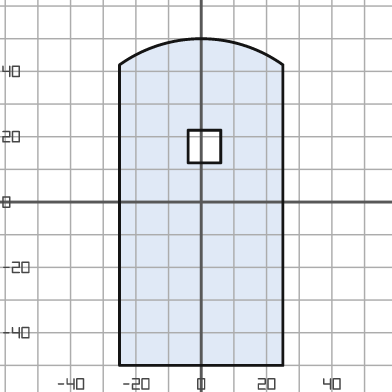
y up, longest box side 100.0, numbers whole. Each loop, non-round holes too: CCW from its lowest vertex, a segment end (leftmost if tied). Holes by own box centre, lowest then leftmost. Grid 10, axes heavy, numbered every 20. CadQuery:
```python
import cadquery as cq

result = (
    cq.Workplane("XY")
    .moveTo(-25.0, -50.0)
    .lineTo(25.0, -50.0)
    .lineTo(25.0, 42.0)
    .threePointArc((0.0, 50.0), (-25.0, 42.0))
    .close()
    .moveTo(-4.0, 12.0)
    .lineTo(6.0, 12.0)
    .lineTo(6.0, 22.0)
    .lineTo(-4.0, 22.0)
    .close()
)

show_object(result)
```